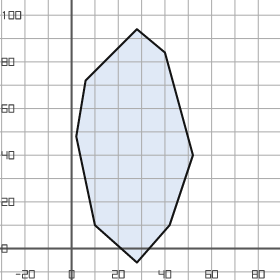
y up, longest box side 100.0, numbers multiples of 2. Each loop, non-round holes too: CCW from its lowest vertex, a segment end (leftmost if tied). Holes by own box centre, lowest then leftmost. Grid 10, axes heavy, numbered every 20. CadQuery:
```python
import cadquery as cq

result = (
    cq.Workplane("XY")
    .moveTo(28.0, -6.0)
    .lineTo(42.0, 10.0)
    .lineTo(52.0, 40.0)
    .lineTo(40.0, 84.0)
    .lineTo(28.0, 94.0)
    .lineTo(6.0, 72.0)
    .lineTo(2.0, 48.0)
    .lineTo(10.0, 10.0)
    .close()
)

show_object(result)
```